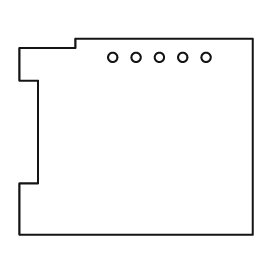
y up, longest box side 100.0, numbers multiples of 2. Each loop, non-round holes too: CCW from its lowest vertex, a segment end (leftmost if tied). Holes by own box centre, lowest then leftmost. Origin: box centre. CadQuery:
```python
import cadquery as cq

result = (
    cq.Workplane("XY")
    .moveTo(-50.0, -42.0)
    .lineTo(50.0, -42.0)
    .lineTo(50.0, 42.0)
    .lineTo(-26.0, 42.0)
    .lineTo(-26.0, 38.0)
    .lineTo(-50.0, 38.0)
    .lineTo(-50.0, 24.0)
    .lineTo(-42.0, 24.0)
    .lineTo(-42.0, -20.0)
    .lineTo(-50.0, -20.0)
    .close()
    .moveTo(-10.0, 34.0)
    .circle(2.0)
    .moveTo(0.0, 34.0)
    .circle(2.0)
    .moveTo(10.0, 34.0)
    .circle(2.0)
    .moveTo(20.0, 34.0)
    .circle(2.0)
    .moveTo(30.0, 34.0)
    .circle(2.0)
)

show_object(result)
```